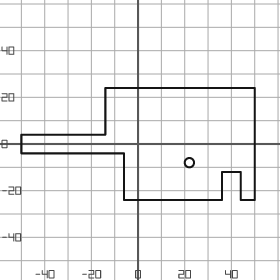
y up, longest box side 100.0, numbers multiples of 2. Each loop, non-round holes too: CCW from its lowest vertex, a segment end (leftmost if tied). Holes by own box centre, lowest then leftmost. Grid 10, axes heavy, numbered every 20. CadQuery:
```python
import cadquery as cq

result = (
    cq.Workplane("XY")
    .moveTo(-6.0, -24.0)
    .lineTo(36.0, -24.0)
    .lineTo(36.0, -12.0)
    .lineTo(44.0, -12.0)
    .lineTo(44.0, -24.0)
    .lineTo(50.0, -24.0)
    .lineTo(50.0, 24.0)
    .lineTo(-14.0, 24.0)
    .lineTo(-14.0, 4.0)
    .lineTo(-50.0, 4.0)
    .lineTo(-50.0, -4.0)
    .lineTo(-6.0, -4.0)
    .close()
    .moveTo(22.0, -8.0)
    .circle(2.0)
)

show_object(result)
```